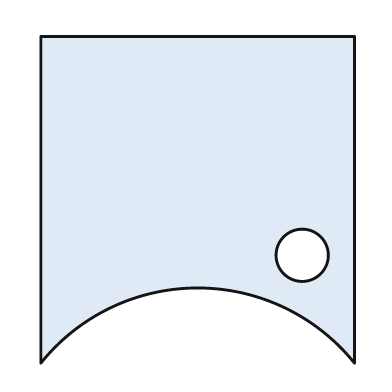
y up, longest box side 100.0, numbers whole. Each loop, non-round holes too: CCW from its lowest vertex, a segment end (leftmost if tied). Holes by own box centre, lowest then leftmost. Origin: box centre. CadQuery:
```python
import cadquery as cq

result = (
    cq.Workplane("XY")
    .moveTo(-48.0, -50.0)
    .threePointArc((0.0, -27.0), (48.0, -50.0))
    .lineTo(48.0, 50.0)
    .lineTo(-48.0, 50.0)
    .close()
    .moveTo(32.0, -17.0)
    .circle(8.0)
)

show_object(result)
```